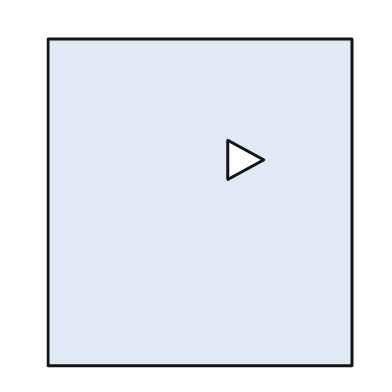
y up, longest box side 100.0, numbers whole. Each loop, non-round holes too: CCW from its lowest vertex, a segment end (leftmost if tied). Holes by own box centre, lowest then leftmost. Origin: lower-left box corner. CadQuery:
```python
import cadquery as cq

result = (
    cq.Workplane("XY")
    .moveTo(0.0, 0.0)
    .lineTo(93.0, 0.0)
    .lineTo(93.0, 100.0)
    .lineTo(0.0, 100.0)
    .close()
    .moveTo(55.0, 57.0)
    .lineTo(66.0, 63.0)
    .lineTo(55.0, 69.0)
    .close()
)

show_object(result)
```